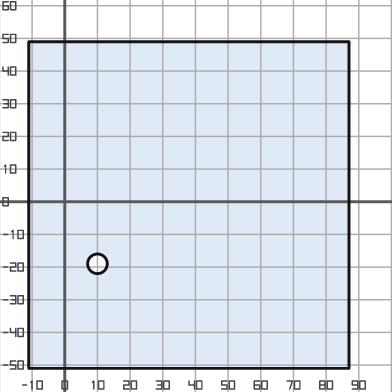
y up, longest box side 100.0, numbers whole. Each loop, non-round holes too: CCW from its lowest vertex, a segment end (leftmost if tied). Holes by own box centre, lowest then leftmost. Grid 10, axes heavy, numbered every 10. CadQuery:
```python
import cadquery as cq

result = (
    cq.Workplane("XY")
    .moveTo(-11.0, -51.0)
    .lineTo(87.0, -51.0)
    .lineTo(87.0, 49.0)
    .lineTo(-11.0, 49.0)
    .close()
    .moveTo(10.0, -19.0)
    .circle(3.0)
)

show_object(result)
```